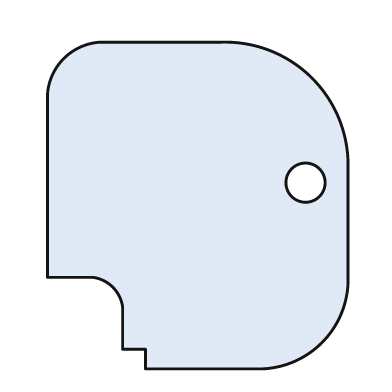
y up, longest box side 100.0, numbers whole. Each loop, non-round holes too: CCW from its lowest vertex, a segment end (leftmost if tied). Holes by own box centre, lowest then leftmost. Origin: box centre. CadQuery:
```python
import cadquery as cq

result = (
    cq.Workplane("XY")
    .moveTo(-16.0, -50.0)
    .lineTo(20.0, -50.0)
    .threePointArc((38.0, -42.0), (46.0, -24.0))
    .lineTo(46.0, 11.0)
    .threePointArc((35.0, 39.0), (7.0, 50.0))
    .lineTo(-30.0, 50.0)
    .threePointArc((-41.0, 45.0), (-46.0, 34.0))
    .lineTo(-46.0, -22.0)
    .lineTo(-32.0, -22.0)
    .threePointArc((-26.0, -25.0), (-23.0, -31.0))
    .lineTo(-23.0, -44.0)
    .lineTo(-16.0, -44.0)
    .close()
    .moveTo(33.0, 7.0)
    .circle(6.0)
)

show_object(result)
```